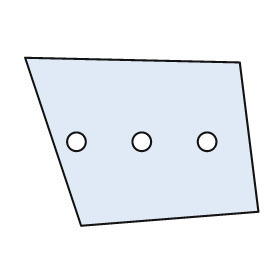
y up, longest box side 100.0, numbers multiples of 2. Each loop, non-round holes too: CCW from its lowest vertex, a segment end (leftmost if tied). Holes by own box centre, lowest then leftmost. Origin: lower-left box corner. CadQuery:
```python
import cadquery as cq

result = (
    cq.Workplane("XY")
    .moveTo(24.0, 0.0)
    .lineTo(100.0, 6.0)
    .lineTo(92.0, 70.0)
    .lineTo(0.0, 72.0)
    .close()
    .moveTo(22.0, 36.0)
    .circle(4.0)
    .moveTo(50.0, 36.0)
    .circle(4.0)
    .moveTo(78.0, 36.0)
    .circle(4.0)
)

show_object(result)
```